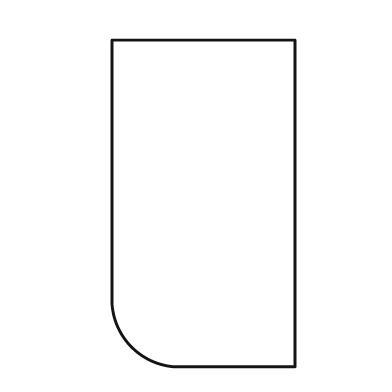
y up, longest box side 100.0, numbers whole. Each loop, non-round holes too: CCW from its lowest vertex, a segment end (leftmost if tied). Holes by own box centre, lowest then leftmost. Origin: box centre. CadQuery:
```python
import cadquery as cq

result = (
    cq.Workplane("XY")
    .moveTo(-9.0, -50.0)
    .lineTo(28.0, -50.0)
    .lineTo(28.0, 50.0)
    .lineTo(-28.0, 50.0)
    .lineTo(-28.0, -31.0)
    .threePointArc((-22.0, -44.0), (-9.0, -50.0))
    .close()
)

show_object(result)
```